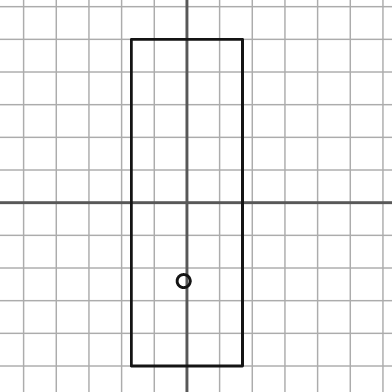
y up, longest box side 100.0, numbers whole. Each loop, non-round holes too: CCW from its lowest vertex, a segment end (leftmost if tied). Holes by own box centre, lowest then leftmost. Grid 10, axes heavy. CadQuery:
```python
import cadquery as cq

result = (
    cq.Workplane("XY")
    .moveTo(-17.0, -50.0)
    .lineTo(17.0, -50.0)
    .lineTo(17.0, 50.0)
    .lineTo(-17.0, 50.0)
    .close()
    .moveTo(-1.0, -24.0)
    .circle(2.0)
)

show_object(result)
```